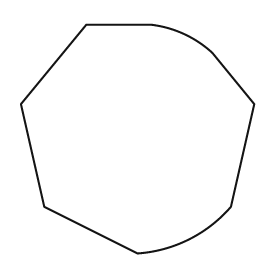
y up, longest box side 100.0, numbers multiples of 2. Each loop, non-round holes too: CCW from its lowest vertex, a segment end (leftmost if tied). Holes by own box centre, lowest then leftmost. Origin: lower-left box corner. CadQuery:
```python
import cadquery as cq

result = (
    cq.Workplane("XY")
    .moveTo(50.0, 0.0)
    .threePointArc((72.0, 6.0), (90.0, 20.0))
    .lineTo(100.0, 64.0)
    .lineTo(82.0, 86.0)
    .threePointArc((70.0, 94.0), (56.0, 98.0))
    .lineTo(28.0, 98.0)
    .lineTo(0.0, 64.0)
    .lineTo(10.0, 20.0)
    .close()
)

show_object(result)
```